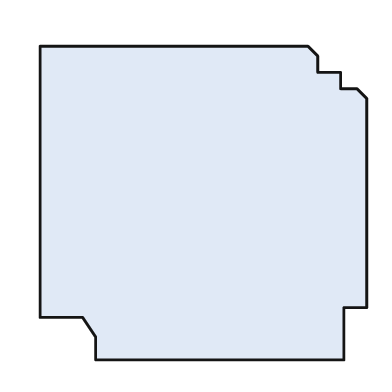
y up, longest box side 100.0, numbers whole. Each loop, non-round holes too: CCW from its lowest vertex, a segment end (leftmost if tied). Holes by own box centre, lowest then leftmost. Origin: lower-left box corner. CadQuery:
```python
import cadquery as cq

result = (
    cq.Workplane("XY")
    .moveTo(17.0, 0.0)
    .lineTo(93.0, 0.0)
    .lineTo(93.0, 16.0)
    .lineTo(100.0, 16.0)
    .lineTo(100.0, 80.0)
    .lineTo(97.0, 83.0)
    .lineTo(92.0, 83.0)
    .lineTo(92.0, 88.0)
    .lineTo(85.0, 88.0)
    .lineTo(85.0, 93.0)
    .lineTo(82.0, 96.0)
    .lineTo(0.0, 96.0)
    .lineTo(0.0, 13.0)
    .lineTo(13.0, 13.0)
    .lineTo(17.0, 7.0)
    .close()
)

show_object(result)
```